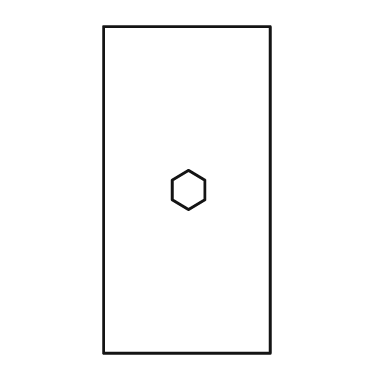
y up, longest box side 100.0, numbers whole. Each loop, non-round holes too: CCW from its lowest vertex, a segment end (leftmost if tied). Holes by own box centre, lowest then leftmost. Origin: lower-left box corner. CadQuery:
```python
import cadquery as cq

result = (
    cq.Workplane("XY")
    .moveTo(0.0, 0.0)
    .lineTo(51.0, 0.0)
    .lineTo(51.0, 100.0)
    .lineTo(0.0, 100.0)
    .close()
    .moveTo(26.0, 44.0)
    .lineTo(31.0, 47.0)
    .lineTo(31.0, 53.0)
    .lineTo(26.0, 56.0)
    .lineTo(21.0, 53.0)
    .lineTo(21.0, 47.0)
    .close()
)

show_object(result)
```